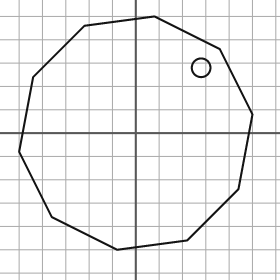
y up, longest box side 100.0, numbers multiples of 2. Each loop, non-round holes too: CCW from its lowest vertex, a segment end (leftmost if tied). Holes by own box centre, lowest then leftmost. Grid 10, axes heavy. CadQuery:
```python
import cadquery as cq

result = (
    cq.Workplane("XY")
    .moveTo(-8.0, -50.0)
    .lineTo(22.0, -46.0)
    .lineTo(44.0, -24.0)
    .lineTo(50.0, 8.0)
    .lineTo(36.0, 36.0)
    .lineTo(8.0, 50.0)
    .lineTo(-22.0, 46.0)
    .lineTo(-44.0, 24.0)
    .lineTo(-50.0, -8.0)
    .lineTo(-36.0, -36.0)
    .close()
    .moveTo(28.0, 28.0)
    .circle(4.0)
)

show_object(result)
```